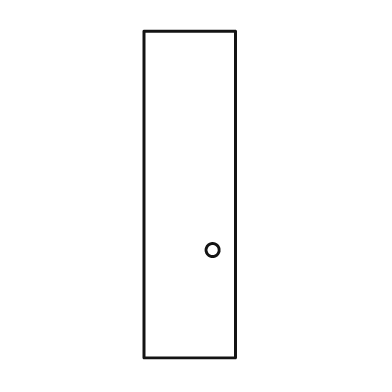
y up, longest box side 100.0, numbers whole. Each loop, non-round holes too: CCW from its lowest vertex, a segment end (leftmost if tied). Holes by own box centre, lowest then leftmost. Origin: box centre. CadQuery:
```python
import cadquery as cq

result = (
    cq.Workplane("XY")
    .moveTo(-14.0, -50.0)
    .lineTo(14.0, -50.0)
    .lineTo(14.0, 50.0)
    .lineTo(-14.0, 50.0)
    .close()
    .moveTo(7.0, -17.0)
    .circle(2.0)
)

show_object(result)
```